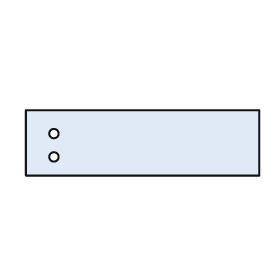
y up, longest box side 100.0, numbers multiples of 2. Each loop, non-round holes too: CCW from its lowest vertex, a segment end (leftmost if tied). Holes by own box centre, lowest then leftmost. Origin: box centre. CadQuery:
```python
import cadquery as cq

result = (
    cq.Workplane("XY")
    .moveTo(-50.0, -14.0)
    .lineTo(50.0, -14.0)
    .lineTo(50.0, 14.0)
    .lineTo(-50.0, 14.0)
    .close()
    .moveTo(-38.0, -6.0)
    .circle(2.0)
    .moveTo(-38.0, 4.0)
    .circle(2.0)
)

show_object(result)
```